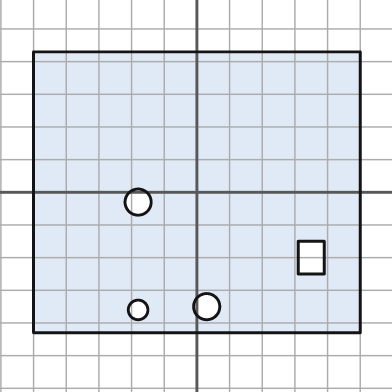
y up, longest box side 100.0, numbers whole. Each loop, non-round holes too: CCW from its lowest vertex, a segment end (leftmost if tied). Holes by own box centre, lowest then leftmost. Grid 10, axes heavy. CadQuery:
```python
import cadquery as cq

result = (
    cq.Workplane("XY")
    .moveTo(-50.0, -43.0)
    .lineTo(50.0, -43.0)
    .lineTo(50.0, 43.0)
    .lineTo(-50.0, 43.0)
    .close()
    .moveTo(-18.0, -36.0)
    .circle(3.0)
    .moveTo(3.0, -35.0)
    .circle(4.0)
    .moveTo(31.0, -25.0)
    .lineTo(39.0, -25.0)
    .lineTo(39.0, -15.0)
    .lineTo(31.0, -15.0)
    .close()
    .moveTo(-18.0, -3.0)
    .circle(4.0)
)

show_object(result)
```